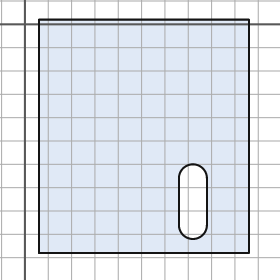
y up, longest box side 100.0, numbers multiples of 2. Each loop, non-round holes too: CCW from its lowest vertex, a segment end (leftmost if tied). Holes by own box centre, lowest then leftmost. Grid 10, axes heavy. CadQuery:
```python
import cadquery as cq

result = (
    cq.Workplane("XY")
    .moveTo(6.0, -98.0)
    .lineTo(96.0, -98.0)
    .lineTo(96.0, 2.0)
    .lineTo(6.0, 2.0)
    .close()
    .moveTo(66.0, -86.0)
    .threePointArc((72.0, -92.0), (78.0, -86.0))
    .lineTo(78.0, -66.0)
    .threePointArc((72.0, -60.0), (66.0, -66.0))
    .close()
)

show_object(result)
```